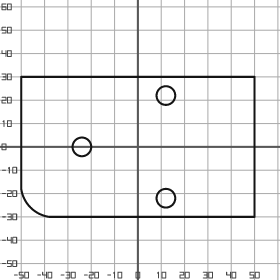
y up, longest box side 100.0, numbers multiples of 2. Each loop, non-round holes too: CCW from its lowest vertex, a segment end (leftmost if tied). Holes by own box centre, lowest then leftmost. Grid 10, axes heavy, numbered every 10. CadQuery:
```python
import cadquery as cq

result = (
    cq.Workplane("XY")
    .moveTo(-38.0, -30.0)
    .lineTo(50.0, -30.0)
    .lineTo(50.0, 30.0)
    .lineTo(-50.0, 30.0)
    .lineTo(-50.0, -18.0)
    .threePointArc((-46.0, -26.0), (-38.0, -30.0))
    .close()
    .moveTo(12.0, -22.0)
    .circle(4.0)
    .moveTo(-24.0, 0.0)
    .circle(4.0)
    .moveTo(12.0, 22.0)
    .circle(4.0)
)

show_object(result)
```